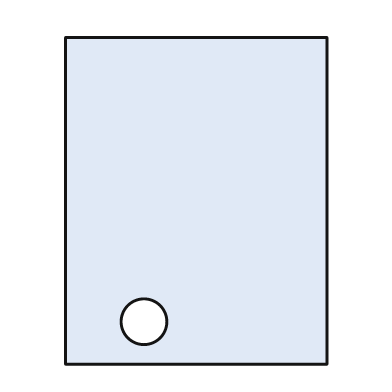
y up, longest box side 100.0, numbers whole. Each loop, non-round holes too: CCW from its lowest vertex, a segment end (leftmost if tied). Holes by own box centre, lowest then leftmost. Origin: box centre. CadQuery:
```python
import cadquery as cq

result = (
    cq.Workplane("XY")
    .moveTo(-40.0, -50.0)
    .lineTo(40.0, -50.0)
    .lineTo(40.0, 50.0)
    .lineTo(-40.0, 50.0)
    .close()
    .moveTo(-16.0, -37.0)
    .circle(7.0)
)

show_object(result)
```